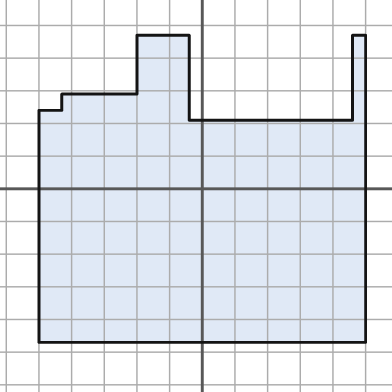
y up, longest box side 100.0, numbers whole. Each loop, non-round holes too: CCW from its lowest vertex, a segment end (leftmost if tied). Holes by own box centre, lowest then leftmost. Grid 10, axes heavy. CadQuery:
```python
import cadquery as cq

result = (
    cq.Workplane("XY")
    .moveTo(-50.0, -47.0)
    .lineTo(50.0, -47.0)
    .lineTo(50.0, 47.0)
    .lineTo(46.0, 47.0)
    .lineTo(46.0, 21.0)
    .lineTo(-4.0, 21.0)
    .lineTo(-4.0, 47.0)
    .lineTo(-20.0, 47.0)
    .lineTo(-20.0, 29.0)
    .lineTo(-43.0, 29.0)
    .lineTo(-43.0, 24.0)
    .lineTo(-50.0, 24.0)
    .close()
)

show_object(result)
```